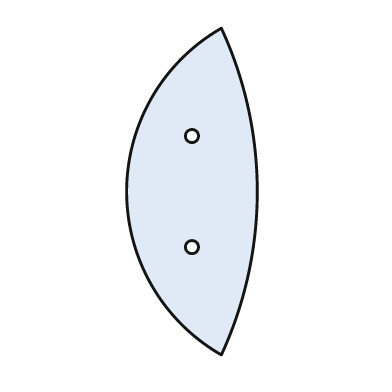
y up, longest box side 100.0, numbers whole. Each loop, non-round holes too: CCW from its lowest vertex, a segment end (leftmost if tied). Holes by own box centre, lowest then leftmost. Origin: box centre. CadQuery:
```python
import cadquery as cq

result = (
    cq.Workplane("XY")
    .moveTo(9.0, -50.0)
    .threePointArc((20.0, 0.0), (9.0, 50.0))
    .threePointArc((-20.0, 0.0), (9.0, -50.0))
    .close()
    .moveTo(0.0, -17.0)
    .circle(2.0)
    .moveTo(0.0, 17.0)
    .circle(2.0)
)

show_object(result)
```